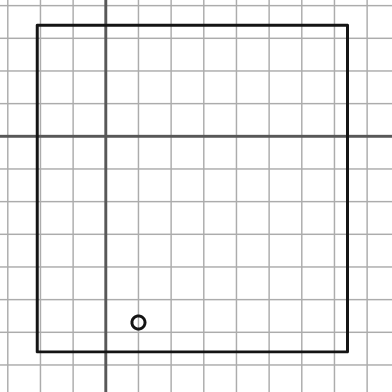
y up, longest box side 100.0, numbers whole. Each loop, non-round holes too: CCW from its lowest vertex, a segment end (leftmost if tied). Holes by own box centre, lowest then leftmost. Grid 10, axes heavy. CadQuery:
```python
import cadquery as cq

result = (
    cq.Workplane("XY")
    .moveTo(-21.0, -66.0)
    .lineTo(74.0, -66.0)
    .lineTo(74.0, 34.0)
    .lineTo(-21.0, 34.0)
    .close()
    .moveTo(10.0, -57.0)
    .circle(2.0)
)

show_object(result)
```